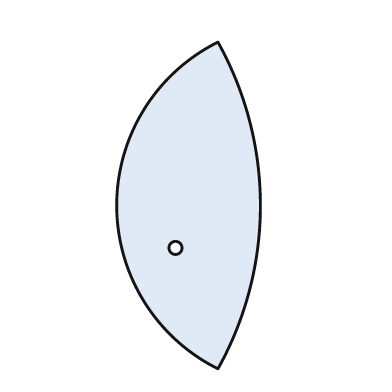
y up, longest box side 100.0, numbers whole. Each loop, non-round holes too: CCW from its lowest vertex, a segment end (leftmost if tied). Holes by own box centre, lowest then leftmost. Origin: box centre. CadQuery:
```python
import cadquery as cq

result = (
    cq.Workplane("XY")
    .moveTo(9.0, -50.0)
    .threePointArc((22.0, 0.0), (9.0, 50.0))
    .threePointArc((-22.0, 0.0), (9.0, -50.0))
    .close()
    .moveTo(-4.0, -13.0)
    .circle(2.0)
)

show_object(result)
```